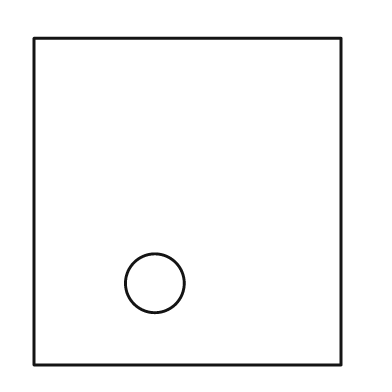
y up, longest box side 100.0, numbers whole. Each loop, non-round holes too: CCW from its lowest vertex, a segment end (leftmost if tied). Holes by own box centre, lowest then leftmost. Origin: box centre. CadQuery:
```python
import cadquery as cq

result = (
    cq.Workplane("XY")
    .moveTo(-47.0, -50.0)
    .lineTo(47.0, -50.0)
    .lineTo(47.0, 50.0)
    .lineTo(-47.0, 50.0)
    .close()
    .moveTo(-10.0, -25.0)
    .circle(9.0)
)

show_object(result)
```